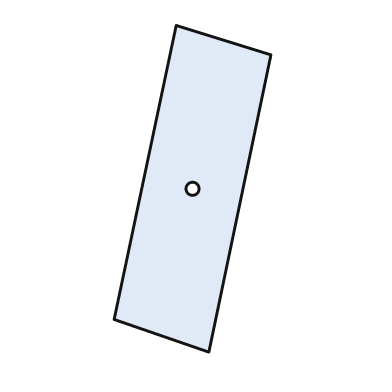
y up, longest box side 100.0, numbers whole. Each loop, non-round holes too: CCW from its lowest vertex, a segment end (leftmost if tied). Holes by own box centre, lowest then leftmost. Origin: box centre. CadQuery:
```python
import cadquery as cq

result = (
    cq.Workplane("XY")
    .moveTo(5.0, -50.0)
    .lineTo(24.0, 41.0)
    .lineTo(-5.0, 50.0)
    .lineTo(-24.0, -40.0)
    .close()
    .moveTo(0.0, 0.0)
    .circle(2.0)
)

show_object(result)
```